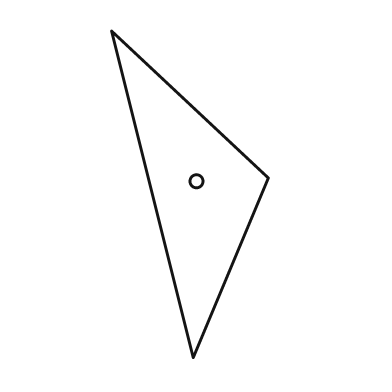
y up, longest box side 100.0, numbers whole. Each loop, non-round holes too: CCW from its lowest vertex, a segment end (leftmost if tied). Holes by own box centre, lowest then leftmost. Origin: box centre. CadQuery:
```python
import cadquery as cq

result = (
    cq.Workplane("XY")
    .moveTo(1.0, -50.0)
    .lineTo(24.0, 5.0)
    .lineTo(-24.0, 50.0)
    .close()
    .moveTo(2.0, 4.0)
    .circle(2.0)
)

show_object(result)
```